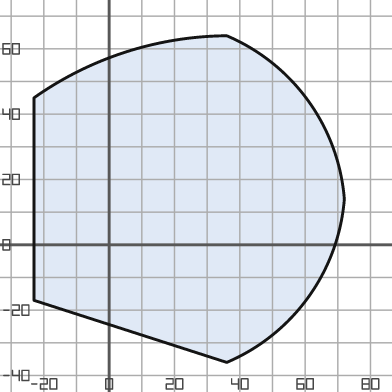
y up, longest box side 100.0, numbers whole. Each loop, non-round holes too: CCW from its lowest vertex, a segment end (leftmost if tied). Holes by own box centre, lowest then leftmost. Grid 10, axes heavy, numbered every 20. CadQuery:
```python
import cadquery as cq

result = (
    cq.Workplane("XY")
    .moveTo(36.0, -36.0)
    .threePointArc((61.0, -16.0), (72.0, 14.0))
    .threePointArc((61.0, 44.0), (36.0, 64.0))
    .threePointArc((5.0, 59.0), (-23.0, 45.0))
    .lineTo(-23.0, -17.0)
    .close()
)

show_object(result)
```